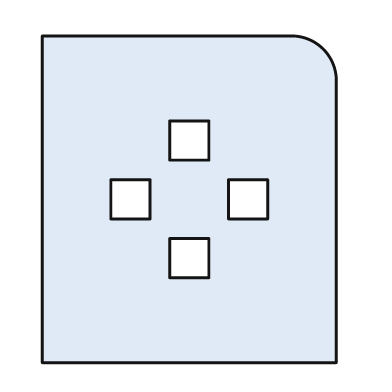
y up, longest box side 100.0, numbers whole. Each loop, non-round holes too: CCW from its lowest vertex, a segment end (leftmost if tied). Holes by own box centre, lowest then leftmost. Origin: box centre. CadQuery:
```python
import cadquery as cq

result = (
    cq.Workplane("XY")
    .moveTo(-45.0, -50.0)
    .lineTo(45.0, -50.0)
    .lineTo(45.0, 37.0)
    .threePointArc((41.0, 46.0), (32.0, 50.0))
    .lineTo(-45.0, 50.0)
    .close()
    .moveTo(-6.0, -24.0)
    .lineTo(6.0, -24.0)
    .lineTo(6.0, -12.0)
    .lineTo(-6.0, -12.0)
    .close()
    .moveTo(-24.0, -6.0)
    .lineTo(-12.0, -6.0)
    .lineTo(-12.0, 6.0)
    .lineTo(-24.0, 6.0)
    .close()
    .moveTo(12.0, -6.0)
    .lineTo(24.0, -6.0)
    .lineTo(24.0, 6.0)
    .lineTo(12.0, 6.0)
    .close()
    .moveTo(-6.0, 12.0)
    .lineTo(6.0, 12.0)
    .lineTo(6.0, 24.0)
    .lineTo(-6.0, 24.0)
    .close()
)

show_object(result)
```